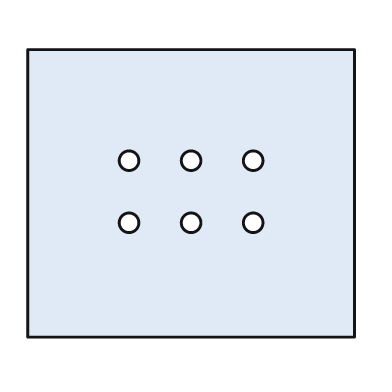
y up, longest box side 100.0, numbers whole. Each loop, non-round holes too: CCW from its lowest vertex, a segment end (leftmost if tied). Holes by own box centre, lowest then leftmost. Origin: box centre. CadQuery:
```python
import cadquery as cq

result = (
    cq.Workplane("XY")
    .moveTo(-50.0, -44.0)
    .lineTo(50.0, -44.0)
    .lineTo(50.0, 44.0)
    .lineTo(-50.0, 44.0)
    .close()
    .moveTo(-19.0, -9.0)
    .circle(3.0)
    .moveTo(0.0, -9.0)
    .circle(3.0)
    .moveTo(19.0, -9.0)
    .circle(3.0)
    .moveTo(-19.0, 10.0)
    .circle(3.0)
    .moveTo(0.0, 10.0)
    .circle(3.0)
    .moveTo(19.0, 10.0)
    .circle(3.0)
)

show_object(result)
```